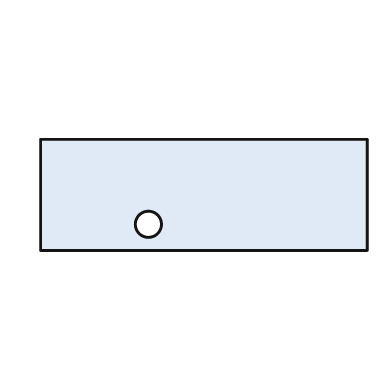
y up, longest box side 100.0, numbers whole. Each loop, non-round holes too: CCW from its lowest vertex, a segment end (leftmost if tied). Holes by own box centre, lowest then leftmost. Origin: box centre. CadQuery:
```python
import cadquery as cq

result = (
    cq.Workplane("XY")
    .moveTo(-50.0, -17.0)
    .lineTo(50.0, -17.0)
    .lineTo(50.0, 17.0)
    .lineTo(-50.0, 17.0)
    .close()
    .moveTo(-17.0, -9.0)
    .circle(4.0)
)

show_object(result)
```